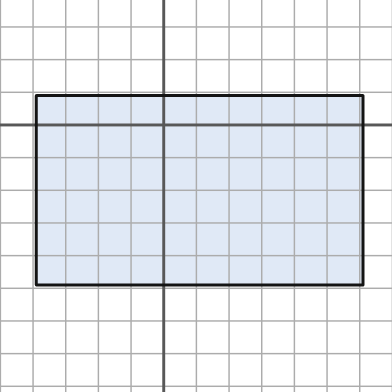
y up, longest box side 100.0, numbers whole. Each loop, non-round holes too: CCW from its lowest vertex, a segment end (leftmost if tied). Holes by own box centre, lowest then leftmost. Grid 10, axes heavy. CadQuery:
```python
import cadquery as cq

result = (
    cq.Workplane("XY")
    .moveTo(-39.0, -49.0)
    .lineTo(61.0, -49.0)
    .lineTo(61.0, 9.0)
    .lineTo(-39.0, 9.0)
    .close()
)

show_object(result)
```